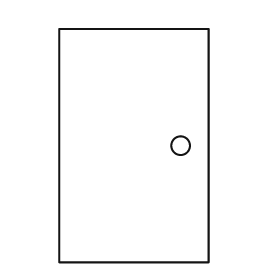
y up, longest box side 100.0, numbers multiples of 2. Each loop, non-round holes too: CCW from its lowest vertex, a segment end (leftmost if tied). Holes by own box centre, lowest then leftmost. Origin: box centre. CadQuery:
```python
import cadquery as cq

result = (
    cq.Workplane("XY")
    .moveTo(-32.0, -50.0)
    .lineTo(32.0, -50.0)
    .lineTo(32.0, 50.0)
    .lineTo(-32.0, 50.0)
    .close()
    .moveTo(20.0, 0.0)
    .circle(4.0)
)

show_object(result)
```